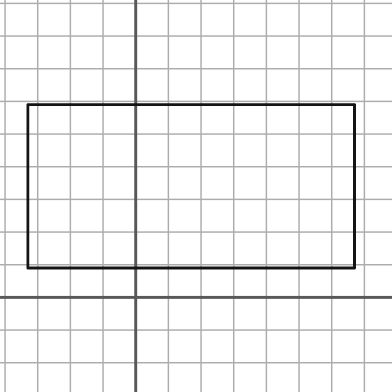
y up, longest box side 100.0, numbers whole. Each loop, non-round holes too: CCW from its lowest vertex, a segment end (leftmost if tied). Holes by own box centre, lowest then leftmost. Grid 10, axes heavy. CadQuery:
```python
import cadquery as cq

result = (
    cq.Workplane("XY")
    .moveTo(-33.0, 9.0)
    .lineTo(67.0, 9.0)
    .lineTo(67.0, 59.0)
    .lineTo(-33.0, 59.0)
    .close()
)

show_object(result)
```